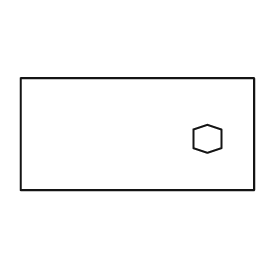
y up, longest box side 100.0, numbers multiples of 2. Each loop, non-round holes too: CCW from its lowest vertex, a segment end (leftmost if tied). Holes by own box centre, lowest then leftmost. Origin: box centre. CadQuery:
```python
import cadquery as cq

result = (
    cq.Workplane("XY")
    .moveTo(-50.0, -24.0)
    .lineTo(50.0, -24.0)
    .lineTo(50.0, 24.0)
    .lineTo(-50.0, 24.0)
    .close()
    .moveTo(30.0, -8.0)
    .lineTo(36.0, -6.0)
    .lineTo(36.0, 2.0)
    .lineTo(30.0, 4.0)
    .lineTo(24.0, 2.0)
    .lineTo(24.0, -6.0)
    .close()
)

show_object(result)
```